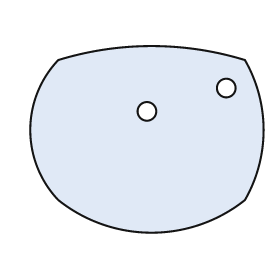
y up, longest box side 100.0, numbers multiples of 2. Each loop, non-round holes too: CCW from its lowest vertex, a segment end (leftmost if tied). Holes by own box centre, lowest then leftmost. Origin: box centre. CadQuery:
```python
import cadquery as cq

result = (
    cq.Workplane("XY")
    .moveTo(-38.0, -26.0)
    .threePointArc((2.0, -40.0), (42.0, -26.0))
    .threePointArc((50.0, 4.0), (42.0, 34.0))
    .threePointArc((2.0, 40.0), (-38.0, 34.0))
    .threePointArc((-50.0, 4.0), (-38.0, -26.0))
    .close()
    .moveTo(0.0, 12.0)
    .circle(4.0)
    .moveTo(34.0, 22.0)
    .circle(4.0)
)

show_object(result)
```